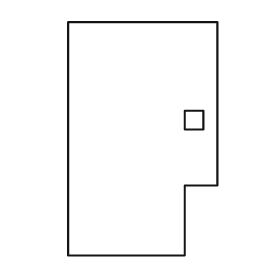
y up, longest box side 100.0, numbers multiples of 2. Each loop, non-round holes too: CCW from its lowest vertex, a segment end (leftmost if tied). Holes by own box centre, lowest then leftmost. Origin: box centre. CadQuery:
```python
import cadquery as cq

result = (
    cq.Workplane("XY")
    .moveTo(-32.0, -50.0)
    .lineTo(18.0, -50.0)
    .lineTo(18.0, -20.0)
    .lineTo(32.0, -20.0)
    .lineTo(32.0, 50.0)
    .lineTo(-32.0, 50.0)
    .close()
    .moveTo(18.0, 4.0)
    .lineTo(26.0, 4.0)
    .lineTo(26.0, 12.0)
    .lineTo(18.0, 12.0)
    .close()
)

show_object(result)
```